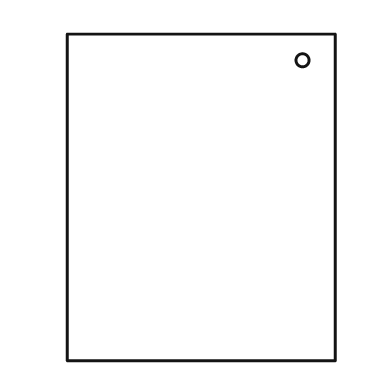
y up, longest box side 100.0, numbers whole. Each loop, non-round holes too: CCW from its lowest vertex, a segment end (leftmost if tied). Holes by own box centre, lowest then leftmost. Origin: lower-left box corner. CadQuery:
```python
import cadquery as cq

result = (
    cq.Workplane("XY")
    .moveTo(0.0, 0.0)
    .lineTo(82.0, 0.0)
    .lineTo(82.0, 100.0)
    .lineTo(0.0, 100.0)
    .close()
    .moveTo(72.0, 92.0)
    .circle(2.0)
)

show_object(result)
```